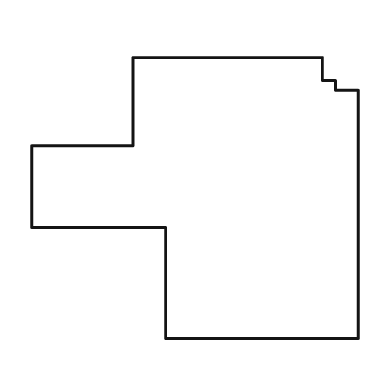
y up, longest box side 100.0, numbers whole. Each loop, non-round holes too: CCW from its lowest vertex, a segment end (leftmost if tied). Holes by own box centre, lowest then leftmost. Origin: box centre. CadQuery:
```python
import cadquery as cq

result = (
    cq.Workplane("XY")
    .moveTo(-9.0, -43.0)
    .lineTo(50.0, -43.0)
    .lineTo(50.0, 33.0)
    .lineTo(43.0, 33.0)
    .lineTo(43.0, 36.0)
    .lineTo(39.0, 36.0)
    .lineTo(39.0, 43.0)
    .lineTo(-19.0, 43.0)
    .lineTo(-19.0, 16.0)
    .lineTo(-50.0, 16.0)
    .lineTo(-50.0, -9.0)
    .lineTo(-9.0, -9.0)
    .close()
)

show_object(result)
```